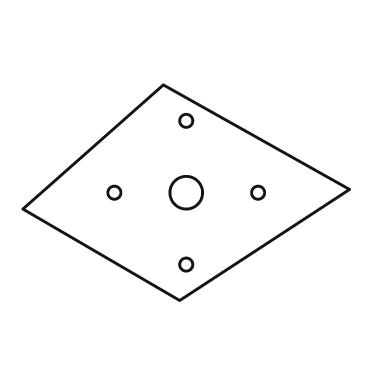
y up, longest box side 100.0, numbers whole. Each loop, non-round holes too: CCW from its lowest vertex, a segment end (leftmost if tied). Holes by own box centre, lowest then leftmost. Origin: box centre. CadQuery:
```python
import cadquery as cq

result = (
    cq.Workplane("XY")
    .moveTo(-2.0, -33.0)
    .lineTo(50.0, 1.0)
    .lineTo(-7.0, 33.0)
    .lineTo(-50.0, -5.0)
    .close()
    .moveTo(0.0, -22.0)
    .circle(2.0)
    .moveTo(-22.0, 0.0)
    .circle(2.0)
    .moveTo(0.0, 0.0)
    .circle(5.0)
    .moveTo(22.0, 0.0)
    .circle(2.0)
    .moveTo(0.0, 22.0)
    .circle(2.0)
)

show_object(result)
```